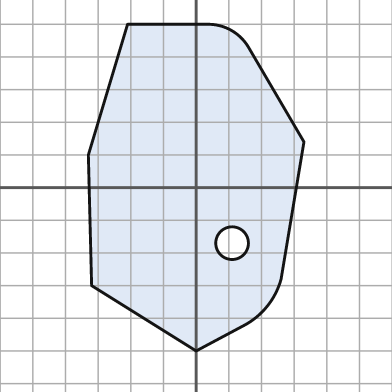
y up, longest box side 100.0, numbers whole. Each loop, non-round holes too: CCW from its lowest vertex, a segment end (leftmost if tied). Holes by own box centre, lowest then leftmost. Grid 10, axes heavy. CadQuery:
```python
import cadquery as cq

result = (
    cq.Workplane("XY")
    .moveTo(0.0, -50.0)
    .lineTo(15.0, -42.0)
    .threePointArc((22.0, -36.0), (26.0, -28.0))
    .lineTo(33.0, 14.0)
    .lineTo(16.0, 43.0)
    .threePointArc((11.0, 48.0), (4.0, 50.0))
    .lineTo(-21.0, 50.0)
    .lineTo(-33.0, 10.0)
    .lineTo(-32.0, -30.0)
    .close()
    .moveTo(11.0, -17.0)
    .circle(5.0)
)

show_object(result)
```